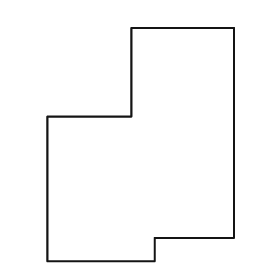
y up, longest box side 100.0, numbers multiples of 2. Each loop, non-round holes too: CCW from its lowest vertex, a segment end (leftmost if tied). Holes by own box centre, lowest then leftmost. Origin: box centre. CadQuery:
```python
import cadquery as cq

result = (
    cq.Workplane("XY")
    .moveTo(-40.0, -50.0)
    .lineTo(6.0, -50.0)
    .lineTo(6.0, -40.0)
    .lineTo(40.0, -40.0)
    .lineTo(40.0, 50.0)
    .lineTo(-4.0, 50.0)
    .lineTo(-4.0, 12.0)
    .lineTo(-40.0, 12.0)
    .close()
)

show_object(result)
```